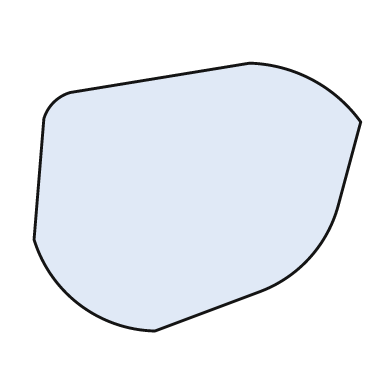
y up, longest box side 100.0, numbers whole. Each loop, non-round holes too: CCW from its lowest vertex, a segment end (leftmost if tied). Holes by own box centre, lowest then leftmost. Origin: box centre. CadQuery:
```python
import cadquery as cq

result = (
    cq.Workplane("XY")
    .moveTo(-13.0, -41.0)
    .lineTo(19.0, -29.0)
    .threePointArc((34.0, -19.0), (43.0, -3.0))
    .lineTo(50.0, 23.0)
    .threePointArc((35.0, 36.0), (16.0, 41.0))
    .lineTo(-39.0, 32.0)
    .threePointArc((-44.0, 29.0), (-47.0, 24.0))
    .lineTo(-50.0, -13.0)
    .threePointArc((-36.0, -33.0), (-13.0, -41.0))
    .close()
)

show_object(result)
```